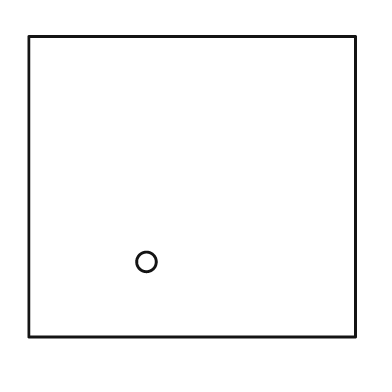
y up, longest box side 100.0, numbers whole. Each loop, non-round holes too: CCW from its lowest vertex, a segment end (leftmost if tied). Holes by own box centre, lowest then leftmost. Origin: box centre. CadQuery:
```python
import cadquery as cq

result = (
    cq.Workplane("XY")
    .moveTo(-50.0, -46.0)
    .lineTo(50.0, -46.0)
    .lineTo(50.0, 46.0)
    .lineTo(-50.0, 46.0)
    .close()
    .moveTo(-14.0, -23.0)
    .circle(3.0)
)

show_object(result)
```